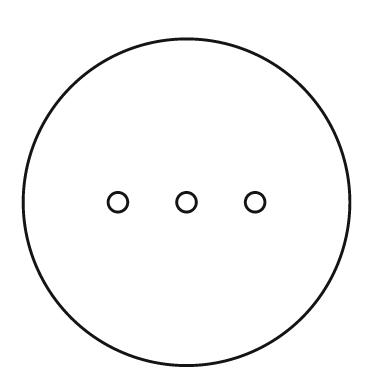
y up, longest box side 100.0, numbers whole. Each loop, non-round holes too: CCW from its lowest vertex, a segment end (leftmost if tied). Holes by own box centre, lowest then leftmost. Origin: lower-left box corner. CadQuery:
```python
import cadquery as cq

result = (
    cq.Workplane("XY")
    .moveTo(50.0, 50.0)
    .circle(50.0)
    .moveTo(29.0, 50.0)
    .circle(3.0)
    .moveTo(50.0, 50.0)
    .circle(3.0)
    .moveTo(71.0, 50.0)
    .circle(3.0)
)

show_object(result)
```